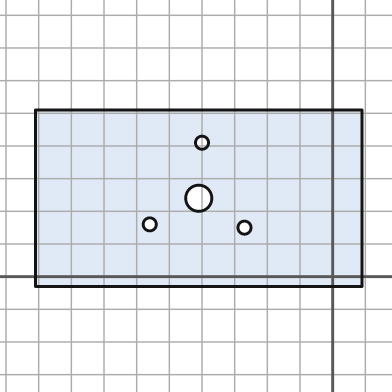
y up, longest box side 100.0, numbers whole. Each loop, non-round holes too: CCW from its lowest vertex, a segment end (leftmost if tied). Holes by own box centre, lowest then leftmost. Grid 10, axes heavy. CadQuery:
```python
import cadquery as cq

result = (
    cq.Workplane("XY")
    .moveTo(-91.0, -3.0)
    .lineTo(9.0, -3.0)
    .lineTo(9.0, 51.0)
    .lineTo(-91.0, 51.0)
    .close()
    .moveTo(-27.0, 15.0)
    .circle(2.0)
    .moveTo(-56.0, 16.0)
    .circle(2.0)
    .moveTo(-41.0, 24.0)
    .circle(4.0)
    .moveTo(-40.0, 41.0)
    .circle(2.0)
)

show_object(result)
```